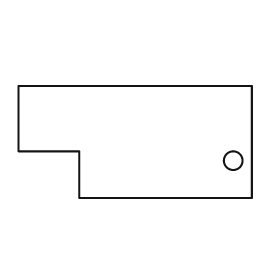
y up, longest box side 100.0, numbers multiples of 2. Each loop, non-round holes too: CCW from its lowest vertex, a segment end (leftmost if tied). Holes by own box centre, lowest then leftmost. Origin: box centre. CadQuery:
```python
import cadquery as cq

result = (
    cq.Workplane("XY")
    .moveTo(-24.0, -24.0)
    .lineTo(50.0, -24.0)
    .lineTo(50.0, 24.0)
    .lineTo(-50.0, 24.0)
    .lineTo(-50.0, -4.0)
    .lineTo(-24.0, -4.0)
    .close()
    .moveTo(42.0, -8.0)
    .circle(4.0)
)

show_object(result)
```